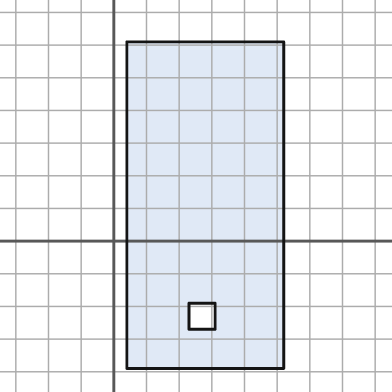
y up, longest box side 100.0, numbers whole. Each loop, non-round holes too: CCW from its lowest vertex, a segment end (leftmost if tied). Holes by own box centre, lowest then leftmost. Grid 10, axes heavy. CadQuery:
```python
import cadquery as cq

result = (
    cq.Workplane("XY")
    .moveTo(4.0, -39.0)
    .lineTo(52.0, -39.0)
    .lineTo(52.0, 61.0)
    .lineTo(4.0, 61.0)
    .close()
    .moveTo(23.0, -27.0)
    .lineTo(31.0, -27.0)
    .lineTo(31.0, -19.0)
    .lineTo(23.0, -19.0)
    .close()
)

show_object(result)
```